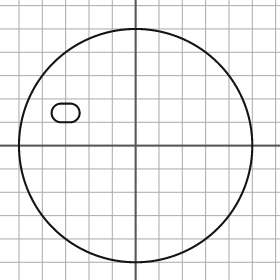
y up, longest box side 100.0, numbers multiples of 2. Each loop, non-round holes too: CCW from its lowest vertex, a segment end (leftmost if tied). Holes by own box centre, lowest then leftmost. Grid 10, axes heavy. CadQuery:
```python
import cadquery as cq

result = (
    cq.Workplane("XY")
    .moveTo(0.0, 0.0)
    .circle(50.0)
    .moveTo(-32.0, 10.0)
    .lineTo(-28.0, 10.0)
    .threePointArc((-24.0, 14.0), (-28.0, 18.0))
    .lineTo(-32.0, 18.0)
    .threePointArc((-36.0, 14.0), (-32.0, 10.0))
    .close()
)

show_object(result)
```